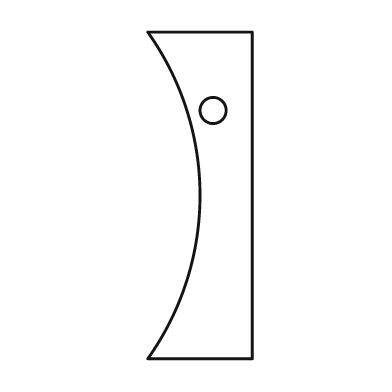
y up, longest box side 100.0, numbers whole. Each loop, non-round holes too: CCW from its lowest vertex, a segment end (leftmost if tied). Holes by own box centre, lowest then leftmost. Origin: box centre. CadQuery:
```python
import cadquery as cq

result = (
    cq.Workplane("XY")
    .moveTo(-16.0, -50.0)
    .lineTo(16.0, -50.0)
    .lineTo(16.0, 50.0)
    .lineTo(-16.0, 50.0)
    .threePointArc((0.0, 0.0), (-16.0, -50.0))
    .close()
    .moveTo(4.0, 26.0)
    .circle(4.0)
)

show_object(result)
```